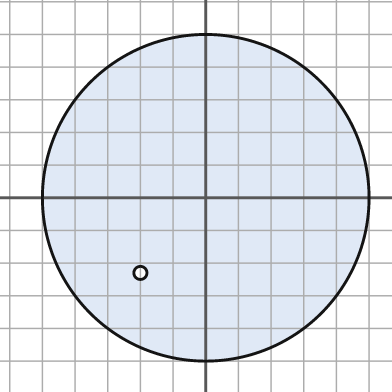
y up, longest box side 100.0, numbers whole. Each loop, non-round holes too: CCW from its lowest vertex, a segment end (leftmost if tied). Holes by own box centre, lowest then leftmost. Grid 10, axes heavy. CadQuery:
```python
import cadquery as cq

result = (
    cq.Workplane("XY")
    .moveTo(0.0, 0.0)
    .circle(50.0)
    .moveTo(-20.0, -23.0)
    .circle(2.0)
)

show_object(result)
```